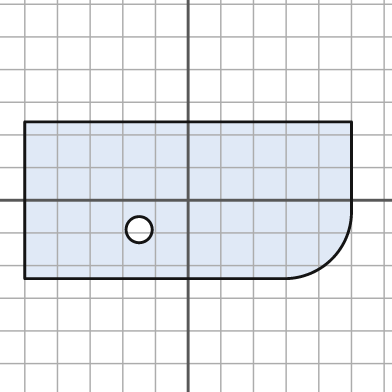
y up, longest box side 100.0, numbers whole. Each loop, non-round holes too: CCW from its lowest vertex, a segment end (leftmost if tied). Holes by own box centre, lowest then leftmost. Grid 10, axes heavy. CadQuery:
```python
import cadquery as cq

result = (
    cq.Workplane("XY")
    .moveTo(-50.0, -24.0)
    .lineTo(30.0, -24.0)
    .threePointArc((44.0, -18.0), (50.0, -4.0))
    .lineTo(50.0, 24.0)
    .lineTo(-50.0, 24.0)
    .close()
    .moveTo(-15.0, -9.0)
    .circle(4.0)
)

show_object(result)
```